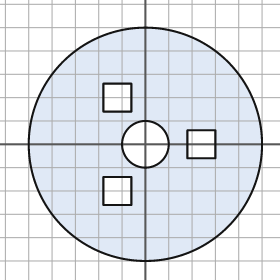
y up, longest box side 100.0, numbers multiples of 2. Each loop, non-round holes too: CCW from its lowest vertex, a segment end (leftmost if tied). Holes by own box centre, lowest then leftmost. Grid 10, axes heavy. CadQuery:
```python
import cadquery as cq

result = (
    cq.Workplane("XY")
    .moveTo(0.0, 0.0)
    .circle(50.0)
    .moveTo(-18.0, -26.0)
    .lineTo(-6.0, -26.0)
    .lineTo(-6.0, -14.0)
    .lineTo(-18.0, -14.0)
    .close()
    .moveTo(0.0, 0.0)
    .circle(10.0)
    .moveTo(18.0, -6.0)
    .lineTo(30.0, -6.0)
    .lineTo(30.0, 6.0)
    .lineTo(18.0, 6.0)
    .close()
    .moveTo(-18.0, 14.0)
    .lineTo(-6.0, 14.0)
    .lineTo(-6.0, 26.0)
    .lineTo(-18.0, 26.0)
    .close()
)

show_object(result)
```